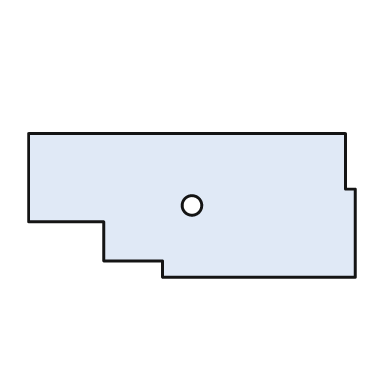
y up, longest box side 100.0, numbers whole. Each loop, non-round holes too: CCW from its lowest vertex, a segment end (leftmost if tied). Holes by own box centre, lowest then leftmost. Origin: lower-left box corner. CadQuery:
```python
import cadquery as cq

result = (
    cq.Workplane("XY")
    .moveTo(41.0, 0.0)
    .lineTo(100.0, 0.0)
    .lineTo(100.0, 27.0)
    .lineTo(97.0, 27.0)
    .lineTo(97.0, 44.0)
    .lineTo(0.0, 44.0)
    .lineTo(0.0, 17.0)
    .lineTo(23.0, 17.0)
    .lineTo(23.0, 5.0)
    .lineTo(41.0, 5.0)
    .close()
    .moveTo(50.0, 22.0)
    .circle(3.0)
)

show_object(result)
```